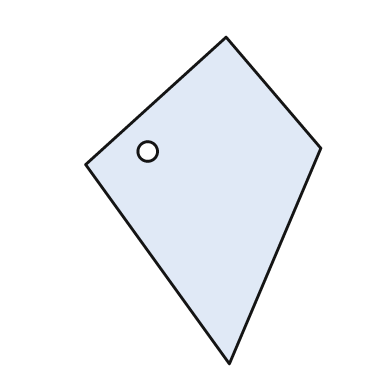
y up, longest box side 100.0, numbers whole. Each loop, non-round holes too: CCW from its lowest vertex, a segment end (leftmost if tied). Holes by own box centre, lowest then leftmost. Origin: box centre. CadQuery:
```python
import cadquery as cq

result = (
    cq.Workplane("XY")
    .moveTo(8.0, -50.0)
    .lineTo(36.0, 16.0)
    .lineTo(7.0, 50.0)
    .lineTo(-36.0, 11.0)
    .close()
    .moveTo(-17.0, 15.0)
    .circle(3.0)
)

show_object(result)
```